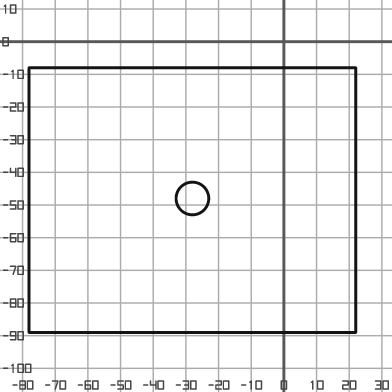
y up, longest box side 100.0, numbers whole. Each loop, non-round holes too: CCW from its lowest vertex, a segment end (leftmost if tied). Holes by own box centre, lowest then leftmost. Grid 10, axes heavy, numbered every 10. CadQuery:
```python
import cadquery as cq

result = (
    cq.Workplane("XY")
    .moveTo(-78.0, -89.0)
    .lineTo(22.0, -89.0)
    .lineTo(22.0, -8.0)
    .lineTo(-78.0, -8.0)
    .close()
    .moveTo(-28.0, -48.0)
    .circle(5.0)
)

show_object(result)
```